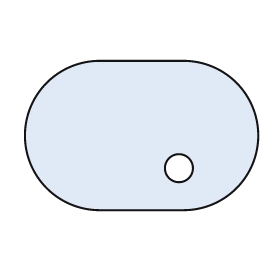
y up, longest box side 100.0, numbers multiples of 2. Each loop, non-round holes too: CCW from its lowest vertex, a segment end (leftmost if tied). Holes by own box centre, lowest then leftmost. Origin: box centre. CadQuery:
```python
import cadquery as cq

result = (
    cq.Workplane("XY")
    .moveTo(-18.0, -32.0)
    .lineTo(18.0, -32.0)
    .threePointArc((50.0, 0.0), (18.0, 32.0))
    .lineTo(-18.0, 32.0)
    .threePointArc((-50.0, 0.0), (-18.0, -32.0))
    .close()
    .moveTo(16.0, -14.0)
    .circle(6.0)
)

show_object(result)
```